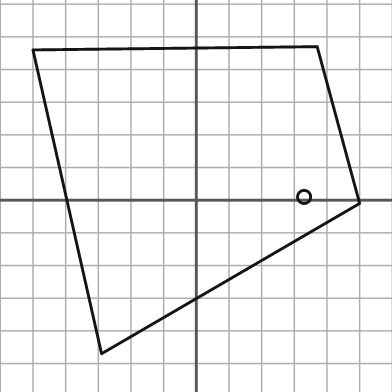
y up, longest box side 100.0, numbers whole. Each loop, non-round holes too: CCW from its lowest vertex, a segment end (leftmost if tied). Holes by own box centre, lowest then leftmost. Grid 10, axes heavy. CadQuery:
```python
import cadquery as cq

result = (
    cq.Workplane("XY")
    .moveTo(-29.0, -47.0)
    .lineTo(50.0, -1.0)
    .lineTo(37.0, 47.0)
    .lineTo(-50.0, 46.0)
    .close()
    .moveTo(33.0, 1.0)
    .circle(2.0)
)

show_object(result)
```